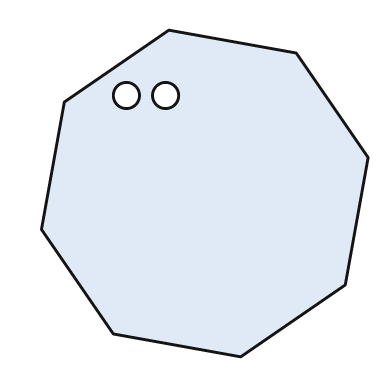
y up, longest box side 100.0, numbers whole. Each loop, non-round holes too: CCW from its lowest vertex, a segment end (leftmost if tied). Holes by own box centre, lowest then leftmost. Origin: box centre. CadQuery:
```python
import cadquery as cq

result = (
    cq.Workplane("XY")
    .moveTo(11.0, -50.0)
    .lineTo(43.0, -28.0)
    .lineTo(50.0, 11.0)
    .lineTo(28.0, 43.0)
    .lineTo(-11.0, 50.0)
    .lineTo(-43.0, 28.0)
    .lineTo(-50.0, -11.0)
    .lineTo(-28.0, -43.0)
    .close()
    .moveTo(-24.0, 30.0)
    .circle(4.0)
    .moveTo(-12.0, 30.0)
    .circle(4.0)
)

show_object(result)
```